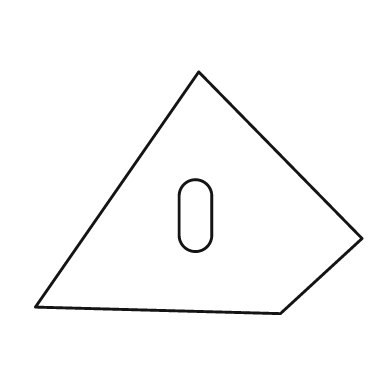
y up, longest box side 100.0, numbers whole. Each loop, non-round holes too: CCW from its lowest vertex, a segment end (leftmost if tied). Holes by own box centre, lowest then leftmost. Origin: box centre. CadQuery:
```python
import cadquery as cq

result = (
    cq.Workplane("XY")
    .moveTo(25.0, -37.0)
    .lineTo(50.0, -14.0)
    .lineTo(0.0, 37.0)
    .lineTo(-50.0, -35.0)
    .close()
    .moveTo(-6.0, -13.0)
    .threePointArc((-1.0, -18.0), (4.0, -13.0))
    .lineTo(4.0, -1.0)
    .threePointArc((-1.0, 4.0), (-6.0, -1.0))
    .close()
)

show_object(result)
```